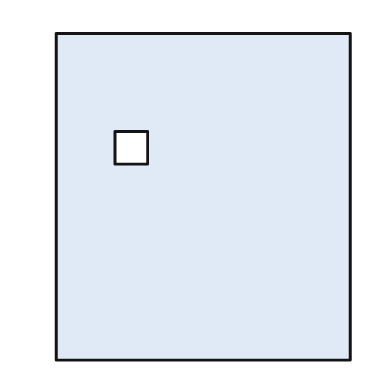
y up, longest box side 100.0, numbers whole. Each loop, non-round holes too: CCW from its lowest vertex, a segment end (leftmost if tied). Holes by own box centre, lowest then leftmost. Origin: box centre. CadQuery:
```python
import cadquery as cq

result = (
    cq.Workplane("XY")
    .moveTo(-45.0, -50.0)
    .lineTo(45.0, -50.0)
    .lineTo(45.0, 50.0)
    .lineTo(-45.0, 50.0)
    .close()
    .moveTo(-27.0, 10.0)
    .lineTo(-17.0, 10.0)
    .lineTo(-17.0, 20.0)
    .lineTo(-27.0, 20.0)
    .close()
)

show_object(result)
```